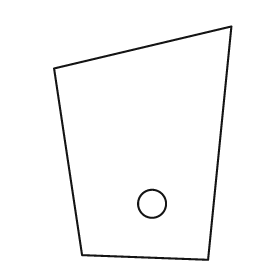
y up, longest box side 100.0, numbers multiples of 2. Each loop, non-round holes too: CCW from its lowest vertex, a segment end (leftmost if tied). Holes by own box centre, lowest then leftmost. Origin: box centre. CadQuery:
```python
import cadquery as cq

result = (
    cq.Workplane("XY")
    .moveTo(28.0, -50.0)
    .lineTo(38.0, 50.0)
    .lineTo(-38.0, 32.0)
    .lineTo(-26.0, -48.0)
    .close()
    .moveTo(4.0, -26.0)
    .circle(6.0)
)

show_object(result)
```